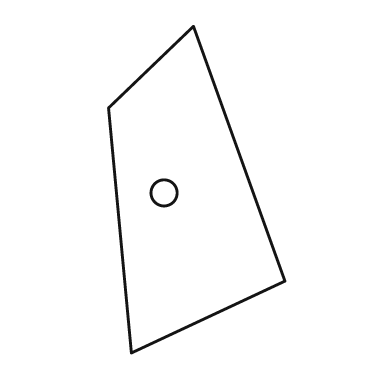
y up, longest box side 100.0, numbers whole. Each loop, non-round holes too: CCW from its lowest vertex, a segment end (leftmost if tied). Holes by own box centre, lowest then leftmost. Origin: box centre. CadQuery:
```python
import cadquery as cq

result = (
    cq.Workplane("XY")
    .moveTo(-20.0, -50.0)
    .lineTo(27.0, -28.0)
    .lineTo(-1.0, 50.0)
    .lineTo(-27.0, 25.0)
    .close()
    .moveTo(-10.0, -1.0)
    .circle(4.0)
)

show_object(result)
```